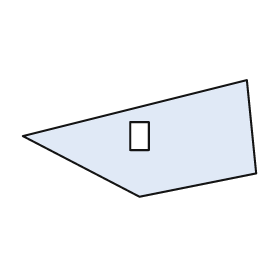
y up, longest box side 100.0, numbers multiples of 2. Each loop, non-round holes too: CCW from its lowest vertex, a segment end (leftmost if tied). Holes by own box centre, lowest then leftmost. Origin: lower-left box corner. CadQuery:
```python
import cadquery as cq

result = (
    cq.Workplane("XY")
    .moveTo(50.0, 0.0)
    .lineTo(100.0, 10.0)
    .lineTo(96.0, 50.0)
    .lineTo(0.0, 26.0)
    .close()
    .moveTo(46.0, 20.0)
    .lineTo(54.0, 20.0)
    .lineTo(54.0, 32.0)
    .lineTo(46.0, 32.0)
    .close()
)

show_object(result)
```